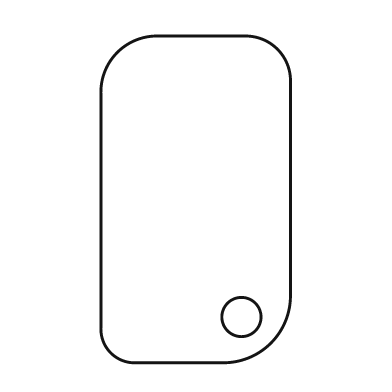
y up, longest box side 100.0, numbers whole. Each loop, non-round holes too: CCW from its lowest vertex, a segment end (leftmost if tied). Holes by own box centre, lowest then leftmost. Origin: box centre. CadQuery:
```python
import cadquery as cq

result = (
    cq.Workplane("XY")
    .moveTo(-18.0, -50.0)
    .lineTo(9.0, -50.0)
    .threePointArc((23.0, -44.0), (29.0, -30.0))
    .lineTo(29.0, 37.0)
    .threePointArc((25.0, 46.0), (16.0, 50.0))
    .lineTo(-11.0, 50.0)
    .threePointArc((-24.0, 45.0), (-29.0, 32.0))
    .lineTo(-29.0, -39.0)
    .threePointArc((-26.0, -47.0), (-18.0, -50.0))
    .close()
    .moveTo(14.0, -36.0)
    .circle(6.0)
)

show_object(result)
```